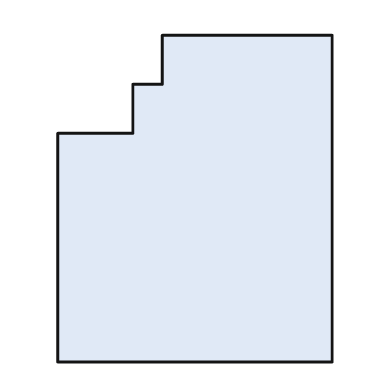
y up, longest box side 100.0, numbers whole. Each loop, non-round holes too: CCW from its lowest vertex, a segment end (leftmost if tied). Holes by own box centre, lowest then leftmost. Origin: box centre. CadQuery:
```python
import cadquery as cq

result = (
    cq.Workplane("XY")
    .moveTo(-42.0, -50.0)
    .lineTo(42.0, -50.0)
    .lineTo(42.0, 50.0)
    .lineTo(-10.0, 50.0)
    .lineTo(-10.0, 35.0)
    .lineTo(-19.0, 35.0)
    .lineTo(-19.0, 20.0)
    .lineTo(-42.0, 20.0)
    .close()
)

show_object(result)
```